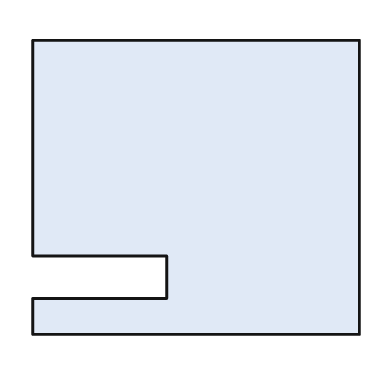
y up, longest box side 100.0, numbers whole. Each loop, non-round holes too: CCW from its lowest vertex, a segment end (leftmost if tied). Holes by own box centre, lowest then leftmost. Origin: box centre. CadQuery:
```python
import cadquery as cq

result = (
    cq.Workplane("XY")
    .moveTo(-50.0, -45.0)
    .lineTo(50.0, -45.0)
    .lineTo(50.0, 45.0)
    .lineTo(-50.0, 45.0)
    .lineTo(-50.0, -21.0)
    .lineTo(-9.0, -21.0)
    .lineTo(-9.0, -34.0)
    .lineTo(-50.0, -34.0)
    .close()
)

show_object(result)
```